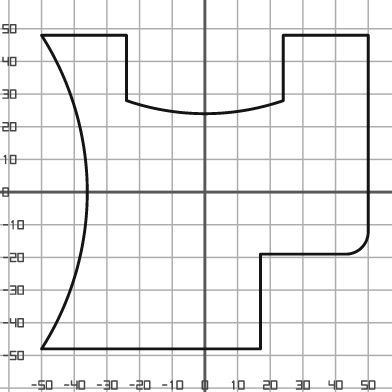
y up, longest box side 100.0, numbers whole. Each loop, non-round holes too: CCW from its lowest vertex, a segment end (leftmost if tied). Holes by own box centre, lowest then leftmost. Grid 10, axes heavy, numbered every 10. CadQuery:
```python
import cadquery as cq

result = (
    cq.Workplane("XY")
    .moveTo(-50.0, -48.0)
    .lineTo(17.0, -48.0)
    .lineTo(17.0, -19.0)
    .lineTo(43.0, -19.0)
    .threePointArc((48.0, -17.0), (50.0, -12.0))
    .lineTo(50.0, 48.0)
    .lineTo(24.0, 48.0)
    .lineTo(24.0, 28.0)
    .threePointArc((0.0, 24.0), (-24.0, 28.0))
    .lineTo(-24.0, 48.0)
    .lineTo(-50.0, 48.0)
    .threePointArc((-36.0, 0.0), (-50.0, -48.0))
    .close()
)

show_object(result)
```